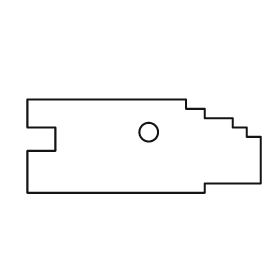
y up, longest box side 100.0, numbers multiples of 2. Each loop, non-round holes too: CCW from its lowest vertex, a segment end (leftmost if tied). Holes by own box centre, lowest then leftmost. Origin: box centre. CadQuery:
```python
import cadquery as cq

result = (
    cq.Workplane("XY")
    .moveTo(-50.0, -20.0)
    .lineTo(26.0, -20.0)
    .lineTo(26.0, -16.0)
    .lineTo(50.0, -16.0)
    .lineTo(50.0, 4.0)
    .lineTo(44.0, 4.0)
    .lineTo(44.0, 8.0)
    .lineTo(38.0, 8.0)
    .lineTo(38.0, 12.0)
    .lineTo(26.0, 12.0)
    .lineTo(26.0, 16.0)
    .lineTo(18.0, 16.0)
    .lineTo(18.0, 20.0)
    .lineTo(-50.0, 20.0)
    .lineTo(-50.0, 8.0)
    .lineTo(-38.0, 8.0)
    .lineTo(-38.0, -2.0)
    .lineTo(-50.0, -2.0)
    .close()
    .moveTo(2.0, 6.0)
    .circle(4.0)
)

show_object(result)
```